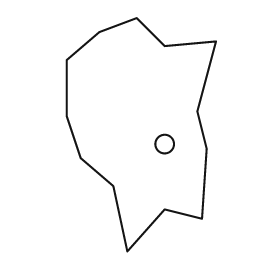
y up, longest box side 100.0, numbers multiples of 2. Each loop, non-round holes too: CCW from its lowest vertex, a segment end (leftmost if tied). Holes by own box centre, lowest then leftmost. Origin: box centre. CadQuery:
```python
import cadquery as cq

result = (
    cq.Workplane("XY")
    .moveTo(-6.0, -50.0)
    .lineTo(10.0, -32.0)
    .lineTo(26.0, -36.0)
    .lineTo(28.0, -6.0)
    .lineTo(24.0, 10.0)
    .lineTo(32.0, 40.0)
    .lineTo(10.0, 38.0)
    .lineTo(-2.0, 50.0)
    .lineTo(-18.0, 44.0)
    .lineTo(-32.0, 32.0)
    .lineTo(-32.0, 8.0)
    .lineTo(-26.0, -10.0)
    .lineTo(-12.0, -22.0)
    .close()
    .moveTo(10.0, -4.0)
    .circle(4.0)
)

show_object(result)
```